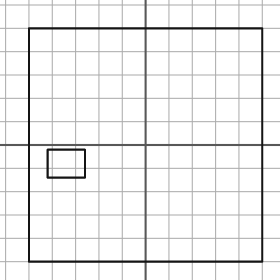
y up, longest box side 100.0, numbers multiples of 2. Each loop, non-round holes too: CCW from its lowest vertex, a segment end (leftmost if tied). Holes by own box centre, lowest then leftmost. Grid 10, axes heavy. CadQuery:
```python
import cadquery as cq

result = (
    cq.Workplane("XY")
    .moveTo(-50.0, -50.0)
    .lineTo(50.0, -50.0)
    .lineTo(50.0, 50.0)
    .lineTo(-50.0, 50.0)
    .close()
    .moveTo(-42.0, -14.0)
    .lineTo(-26.0, -14.0)
    .lineTo(-26.0, -2.0)
    .lineTo(-42.0, -2.0)
    .close()
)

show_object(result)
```